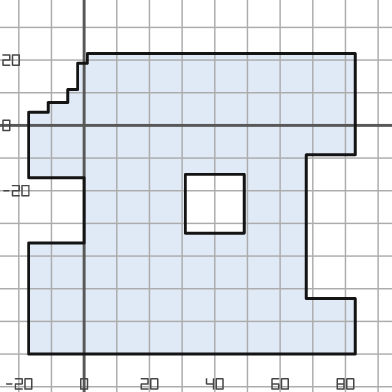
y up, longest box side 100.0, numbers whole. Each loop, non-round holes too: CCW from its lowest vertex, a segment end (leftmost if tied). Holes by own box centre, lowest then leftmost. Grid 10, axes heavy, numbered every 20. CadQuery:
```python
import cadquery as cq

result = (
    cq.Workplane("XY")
    .moveTo(-17.0, -70.0)
    .lineTo(83.0, -70.0)
    .lineTo(83.0, -53.0)
    .lineTo(68.0, -53.0)
    .lineTo(68.0, -9.0)
    .lineTo(83.0, -9.0)
    .lineTo(83.0, 22.0)
    .lineTo(1.0, 22.0)
    .lineTo(1.0, 19.0)
    .lineTo(-2.0, 19.0)
    .lineTo(-2.0, 11.0)
    .lineTo(-5.0, 11.0)
    .lineTo(-5.0, 7.0)
    .lineTo(-11.0, 7.0)
    .lineTo(-11.0, 4.0)
    .lineTo(-17.0, 4.0)
    .lineTo(-17.0, -16.0)
    .lineTo(0.0, -16.0)
    .lineTo(0.0, -36.0)
    .lineTo(-17.0, -36.0)
    .close()
    .moveTo(31.0, -33.0)
    .lineTo(49.0, -33.0)
    .lineTo(49.0, -15.0)
    .lineTo(31.0, -15.0)
    .close()
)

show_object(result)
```